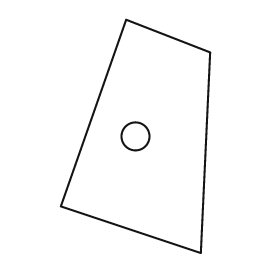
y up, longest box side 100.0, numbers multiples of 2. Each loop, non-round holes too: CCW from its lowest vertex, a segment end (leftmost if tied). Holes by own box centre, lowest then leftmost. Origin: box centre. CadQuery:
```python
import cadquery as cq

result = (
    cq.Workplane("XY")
    .moveTo(28.0, -50.0)
    .lineTo(32.0, 36.0)
    .lineTo(-4.0, 50.0)
    .lineTo(-32.0, -30.0)
    .close()
    .moveTo(0.0, 0.0)
    .circle(6.0)
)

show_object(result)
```